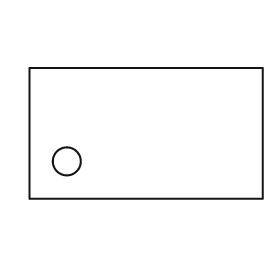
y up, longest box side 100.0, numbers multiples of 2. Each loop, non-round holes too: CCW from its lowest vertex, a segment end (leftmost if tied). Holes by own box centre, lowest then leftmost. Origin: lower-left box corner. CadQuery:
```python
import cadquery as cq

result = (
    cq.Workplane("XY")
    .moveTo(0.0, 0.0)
    .lineTo(100.0, 0.0)
    .lineTo(100.0, 56.0)
    .lineTo(0.0, 56.0)
    .close()
    .moveTo(16.0, 16.0)
    .circle(6.0)
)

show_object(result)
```